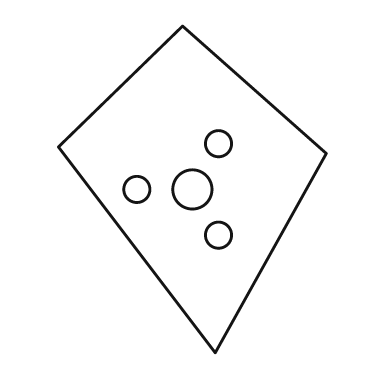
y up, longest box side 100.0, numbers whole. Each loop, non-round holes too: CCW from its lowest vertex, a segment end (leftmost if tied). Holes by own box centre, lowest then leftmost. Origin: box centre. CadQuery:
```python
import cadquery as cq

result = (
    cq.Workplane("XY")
    .moveTo(7.0, -50.0)
    .lineTo(41.0, 11.0)
    .lineTo(-3.0, 50.0)
    .lineTo(-41.0, 13.0)
    .close()
    .moveTo(8.0, -14.0)
    .circle(4.0)
    .moveTo(-17.0, 0.0)
    .circle(4.0)
    .moveTo(0.0, 0.0)
    .circle(6.0)
    .moveTo(8.0, 14.0)
    .circle(4.0)
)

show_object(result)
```